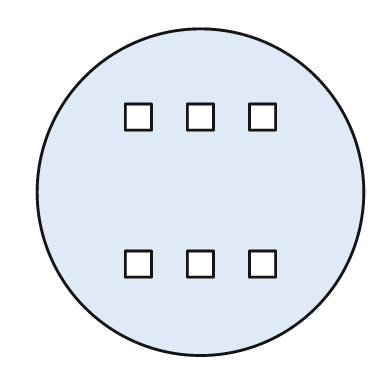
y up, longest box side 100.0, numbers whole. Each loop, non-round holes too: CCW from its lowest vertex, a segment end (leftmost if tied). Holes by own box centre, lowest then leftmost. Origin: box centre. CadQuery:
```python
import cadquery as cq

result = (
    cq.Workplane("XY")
    .moveTo(0.0, 0.0)
    .circle(50.0)
    .moveTo(-23.0, -26.0)
    .lineTo(-15.0, -26.0)
    .lineTo(-15.0, -18.0)
    .lineTo(-23.0, -18.0)
    .close()
    .moveTo(-4.0, -26.0)
    .lineTo(4.0, -26.0)
    .lineTo(4.0, -18.0)
    .lineTo(-4.0, -18.0)
    .close()
    .moveTo(15.0, -26.0)
    .lineTo(23.0, -26.0)
    .lineTo(23.0, -18.0)
    .lineTo(15.0, -18.0)
    .close()
    .moveTo(-23.0, 19.0)
    .lineTo(-15.0, 19.0)
    .lineTo(-15.0, 27.0)
    .lineTo(-23.0, 27.0)
    .close()
    .moveTo(-4.0, 19.0)
    .lineTo(4.0, 19.0)
    .lineTo(4.0, 27.0)
    .lineTo(-4.0, 27.0)
    .close()
    .moveTo(15.0, 19.0)
    .lineTo(23.0, 19.0)
    .lineTo(23.0, 27.0)
    .lineTo(15.0, 27.0)
    .close()
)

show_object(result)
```